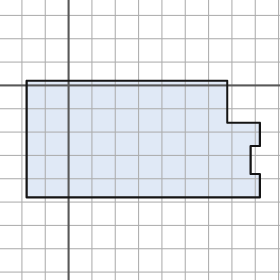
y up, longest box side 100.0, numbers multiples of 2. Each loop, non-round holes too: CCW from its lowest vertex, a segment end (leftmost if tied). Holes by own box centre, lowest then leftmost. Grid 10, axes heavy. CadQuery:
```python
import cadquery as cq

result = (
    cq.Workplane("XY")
    .moveTo(-18.0, -48.0)
    .lineTo(82.0, -48.0)
    .lineTo(82.0, -38.0)
    .lineTo(78.0, -38.0)
    .lineTo(78.0, -26.0)
    .lineTo(82.0, -26.0)
    .lineTo(82.0, -16.0)
    .lineTo(68.0, -16.0)
    .lineTo(68.0, 2.0)
    .lineTo(-18.0, 2.0)
    .close()
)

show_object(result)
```